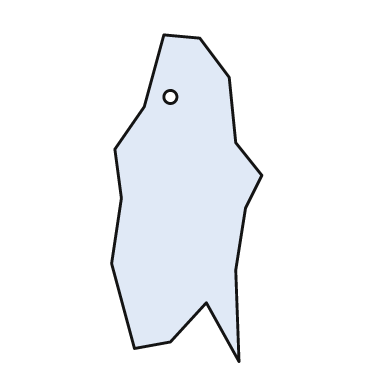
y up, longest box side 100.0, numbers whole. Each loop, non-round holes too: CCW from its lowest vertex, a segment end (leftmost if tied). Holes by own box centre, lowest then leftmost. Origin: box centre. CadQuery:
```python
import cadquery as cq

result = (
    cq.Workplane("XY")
    .moveTo(16.0, -50.0)
    .lineTo(15.0, -22.0)
    .lineTo(18.0, -3.0)
    .lineTo(23.0, 7.0)
    .lineTo(15.0, 17.0)
    .lineTo(13.0, 37.0)
    .lineTo(4.0, 49.0)
    .lineTo(-7.0, 50.0)
    .lineTo(-13.0, 28.0)
    .lineTo(-22.0, 15.0)
    .lineTo(-20.0, 0.0)
    .lineTo(-23.0, -20.0)
    .lineTo(-16.0, -46.0)
    .lineTo(-5.0, -44.0)
    .lineTo(6.0, -32.0)
    .close()
    .moveTo(-5.0, 31.0)
    .circle(2.0)
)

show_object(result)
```